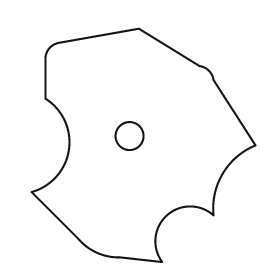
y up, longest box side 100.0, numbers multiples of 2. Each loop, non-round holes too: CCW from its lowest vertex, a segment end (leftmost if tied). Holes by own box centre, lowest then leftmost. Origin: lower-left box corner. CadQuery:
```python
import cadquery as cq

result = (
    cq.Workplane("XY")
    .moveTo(56.0, 0.0)
    .threePointArc((58.0, 20.0), (78.0, 20.0))
    .threePointArc((82.0, 38.0), (96.0, 50.0))
    .lineTo(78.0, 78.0)
    .threePointArc((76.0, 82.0), (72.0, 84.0))
    .lineTo(46.0, 100.0)
    .lineTo(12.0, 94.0)
    .threePointArc((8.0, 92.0), (6.0, 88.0))
    .lineTo(6.0, 70.0)
    .threePointArc((16.0, 48.0), (0.0, 30.0))
    .lineTo(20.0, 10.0)
    .threePointArc((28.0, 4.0), (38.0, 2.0))
    .close()
    .moveTo(42.0, 54.0)
    .circle(6.0)
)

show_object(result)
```